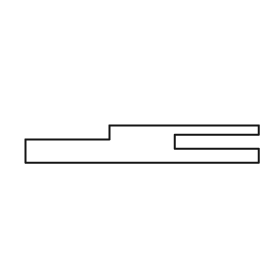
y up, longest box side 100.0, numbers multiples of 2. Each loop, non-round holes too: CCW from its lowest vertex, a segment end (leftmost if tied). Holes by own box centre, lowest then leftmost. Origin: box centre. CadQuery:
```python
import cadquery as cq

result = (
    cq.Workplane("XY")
    .moveTo(-50.0, -8.0)
    .lineTo(50.0, -8.0)
    .lineTo(50.0, -2.0)
    .lineTo(14.0, -2.0)
    .lineTo(14.0, 4.0)
    .lineTo(50.0, 4.0)
    .lineTo(50.0, 8.0)
    .lineTo(-14.0, 8.0)
    .lineTo(-14.0, 2.0)
    .lineTo(-50.0, 2.0)
    .close()
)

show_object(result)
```